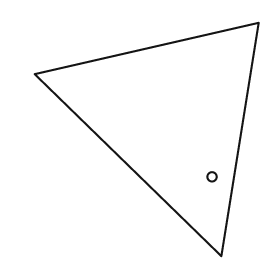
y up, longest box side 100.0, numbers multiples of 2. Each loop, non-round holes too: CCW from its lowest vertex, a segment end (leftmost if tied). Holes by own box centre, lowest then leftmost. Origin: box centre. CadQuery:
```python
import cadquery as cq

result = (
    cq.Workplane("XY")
    .moveTo(32.0, -50.0)
    .lineTo(48.0, 50.0)
    .lineTo(-48.0, 28.0)
    .close()
    .moveTo(28.0, -16.0)
    .circle(2.0)
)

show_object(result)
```